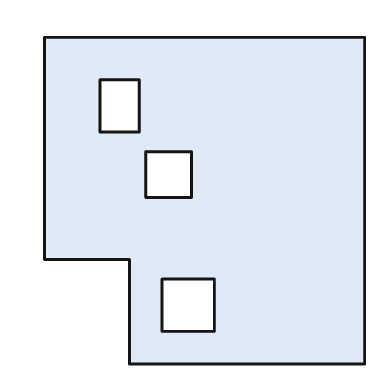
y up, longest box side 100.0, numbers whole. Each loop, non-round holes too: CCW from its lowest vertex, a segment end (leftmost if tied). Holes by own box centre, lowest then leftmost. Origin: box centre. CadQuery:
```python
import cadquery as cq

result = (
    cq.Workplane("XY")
    .moveTo(-23.0, -50.0)
    .lineTo(49.0, -50.0)
    .lineTo(49.0, 50.0)
    .lineTo(-49.0, 50.0)
    .lineTo(-49.0, -18.0)
    .lineTo(-23.0, -18.0)
    .close()
    .moveTo(-13.0, -40.0)
    .lineTo(3.0, -40.0)
    .lineTo(3.0, -24.0)
    .lineTo(-13.0, -24.0)
    .close()
    .moveTo(-18.0, 1.0)
    .lineTo(-4.0, 1.0)
    .lineTo(-4.0, 15.0)
    .lineTo(-18.0, 15.0)
    .close()
    .moveTo(-32.0, 21.0)
    .lineTo(-20.0, 21.0)
    .lineTo(-20.0, 37.0)
    .lineTo(-32.0, 37.0)
    .close()
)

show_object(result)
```